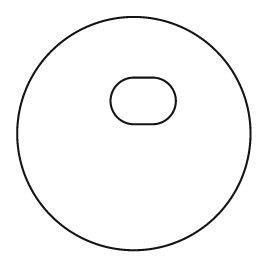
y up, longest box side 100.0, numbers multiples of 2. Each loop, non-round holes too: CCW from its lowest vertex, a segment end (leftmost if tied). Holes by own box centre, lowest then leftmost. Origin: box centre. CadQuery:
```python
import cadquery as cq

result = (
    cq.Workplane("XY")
    .moveTo(0.0, 0.0)
    .circle(50.0)
    .moveTo(0.0, 4.0)
    .lineTo(8.0, 4.0)
    .threePointArc((18.0, 14.0), (8.0, 24.0))
    .lineTo(0.0, 24.0)
    .threePointArc((-10.0, 14.0), (0.0, 4.0))
    .close()
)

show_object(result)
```